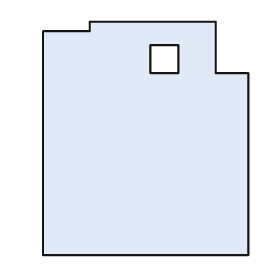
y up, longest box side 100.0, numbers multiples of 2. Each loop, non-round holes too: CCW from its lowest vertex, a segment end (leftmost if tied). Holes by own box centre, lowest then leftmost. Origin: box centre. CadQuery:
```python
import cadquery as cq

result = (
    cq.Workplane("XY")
    .moveTo(-44.0, -50.0)
    .lineTo(44.0, -50.0)
    .lineTo(44.0, 28.0)
    .lineTo(30.0, 28.0)
    .lineTo(30.0, 50.0)
    .lineTo(-24.0, 50.0)
    .lineTo(-24.0, 46.0)
    .lineTo(-44.0, 46.0)
    .close()
    .moveTo(2.0, 28.0)
    .lineTo(14.0, 28.0)
    .lineTo(14.0, 40.0)
    .lineTo(2.0, 40.0)
    .close()
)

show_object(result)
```